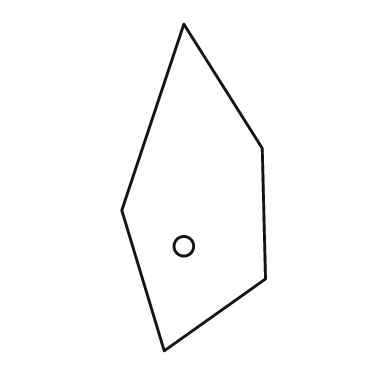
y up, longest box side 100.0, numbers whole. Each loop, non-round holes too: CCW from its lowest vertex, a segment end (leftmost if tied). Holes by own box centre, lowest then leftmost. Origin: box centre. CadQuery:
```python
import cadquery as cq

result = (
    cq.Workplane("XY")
    .moveTo(-9.0, -50.0)
    .lineTo(22.0, -28.0)
    .lineTo(21.0, 12.0)
    .lineTo(-3.0, 50.0)
    .lineTo(-22.0, -7.0)
    .close()
    .moveTo(-3.0, -18.0)
    .circle(3.0)
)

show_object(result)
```